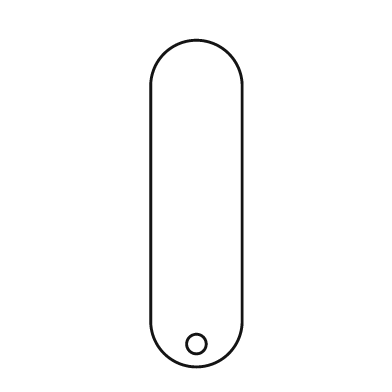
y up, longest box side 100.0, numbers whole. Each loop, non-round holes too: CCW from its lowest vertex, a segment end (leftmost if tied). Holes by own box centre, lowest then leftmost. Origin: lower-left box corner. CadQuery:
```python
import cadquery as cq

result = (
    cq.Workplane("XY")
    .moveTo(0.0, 14.0)
    .threePointArc((14.0, 0.0), (28.0, 14.0))
    .lineTo(28.0, 86.0)
    .threePointArc((14.0, 100.0), (0.0, 86.0))
    .close()
    .moveTo(14.0, 7.0)
    .circle(3.0)
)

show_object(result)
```